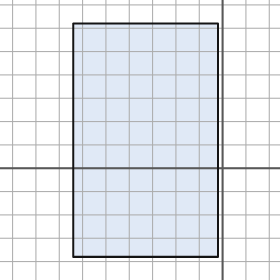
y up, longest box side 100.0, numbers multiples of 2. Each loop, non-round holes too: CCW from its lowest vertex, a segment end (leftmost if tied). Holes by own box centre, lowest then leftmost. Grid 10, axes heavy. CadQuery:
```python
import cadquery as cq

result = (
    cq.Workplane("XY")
    .moveTo(-64.0, -38.0)
    .lineTo(-2.0, -38.0)
    .lineTo(-2.0, 62.0)
    .lineTo(-64.0, 62.0)
    .close()
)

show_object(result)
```